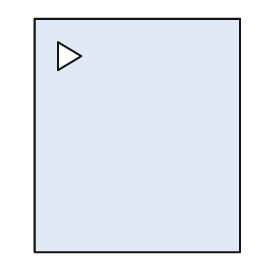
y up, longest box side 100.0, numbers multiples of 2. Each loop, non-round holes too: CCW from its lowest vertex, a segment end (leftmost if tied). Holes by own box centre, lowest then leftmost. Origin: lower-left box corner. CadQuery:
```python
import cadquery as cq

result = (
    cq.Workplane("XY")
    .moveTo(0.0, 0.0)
    .lineTo(88.0, 0.0)
    .lineTo(88.0, 100.0)
    .lineTo(0.0, 100.0)
    .close()
    .moveTo(10.0, 78.0)
    .lineTo(20.0, 84.0)
    .lineTo(10.0, 90.0)
    .close()
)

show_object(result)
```